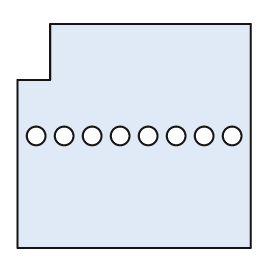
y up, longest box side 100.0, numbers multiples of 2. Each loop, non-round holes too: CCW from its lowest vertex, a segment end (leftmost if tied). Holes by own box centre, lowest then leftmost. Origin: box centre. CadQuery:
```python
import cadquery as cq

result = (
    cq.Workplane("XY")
    .moveTo(-50.0, -48.0)
    .lineTo(50.0, -48.0)
    .lineTo(50.0, 48.0)
    .lineTo(-36.0, 48.0)
    .lineTo(-36.0, 24.0)
    .lineTo(-50.0, 24.0)
    .close()
    .moveTo(-42.0, 0.0)
    .circle(4.0)
    .moveTo(-30.0, 0.0)
    .circle(4.0)
    .moveTo(-18.0, 0.0)
    .circle(4.0)
    .moveTo(-6.0, 0.0)
    .circle(4.0)
    .moveTo(6.0, 0.0)
    .circle(4.0)
    .moveTo(18.0, 0.0)
    .circle(4.0)
    .moveTo(30.0, 0.0)
    .circle(4.0)
    .moveTo(42.0, 0.0)
    .circle(4.0)
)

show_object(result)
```